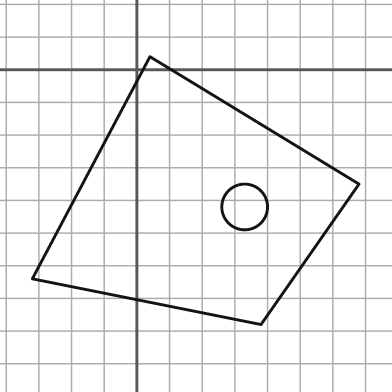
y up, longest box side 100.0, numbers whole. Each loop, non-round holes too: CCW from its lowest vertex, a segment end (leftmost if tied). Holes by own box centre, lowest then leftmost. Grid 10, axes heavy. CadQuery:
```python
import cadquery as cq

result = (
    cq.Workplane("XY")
    .moveTo(38.0, -78.0)
    .lineTo(68.0, -35.0)
    .lineTo(4.0, 4.0)
    .lineTo(-32.0, -64.0)
    .close()
    .moveTo(33.0, -42.0)
    .circle(7.0)
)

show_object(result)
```